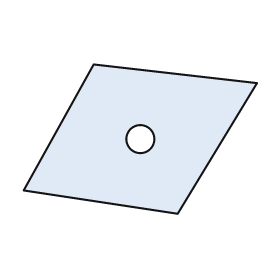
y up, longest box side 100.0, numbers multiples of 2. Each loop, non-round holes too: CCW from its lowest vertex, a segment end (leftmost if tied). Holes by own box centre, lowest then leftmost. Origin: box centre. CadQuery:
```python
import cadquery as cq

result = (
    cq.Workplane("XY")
    .moveTo(16.0, -32.0)
    .lineTo(50.0, 24.0)
    .lineTo(-20.0, 32.0)
    .lineTo(-50.0, -22.0)
    .close()
    .moveTo(0.0, 0.0)
    .circle(6.0)
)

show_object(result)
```